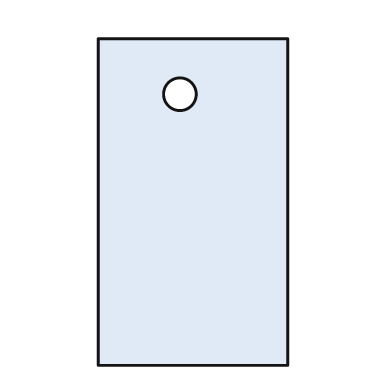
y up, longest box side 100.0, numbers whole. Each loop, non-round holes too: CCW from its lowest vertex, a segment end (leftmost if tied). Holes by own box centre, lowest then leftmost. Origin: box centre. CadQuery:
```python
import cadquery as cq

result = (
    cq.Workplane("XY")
    .moveTo(-29.0, -50.0)
    .lineTo(29.0, -50.0)
    .lineTo(29.0, 50.0)
    .lineTo(-29.0, 50.0)
    .close()
    .moveTo(-4.0, 33.0)
    .circle(5.0)
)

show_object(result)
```